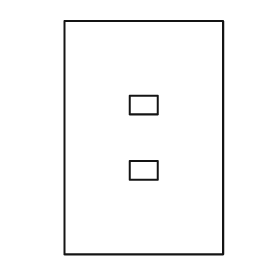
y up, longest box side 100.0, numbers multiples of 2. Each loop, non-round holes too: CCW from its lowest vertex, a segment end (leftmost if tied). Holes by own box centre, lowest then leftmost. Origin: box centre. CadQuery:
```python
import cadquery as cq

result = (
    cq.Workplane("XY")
    .moveTo(-34.0, -50.0)
    .lineTo(34.0, -50.0)
    .lineTo(34.0, 50.0)
    .lineTo(-34.0, 50.0)
    .close()
    .moveTo(-6.0, -18.0)
    .lineTo(6.0, -18.0)
    .lineTo(6.0, -10.0)
    .lineTo(-6.0, -10.0)
    .close()
    .moveTo(-6.0, 10.0)
    .lineTo(6.0, 10.0)
    .lineTo(6.0, 18.0)
    .lineTo(-6.0, 18.0)
    .close()
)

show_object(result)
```